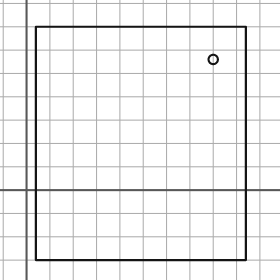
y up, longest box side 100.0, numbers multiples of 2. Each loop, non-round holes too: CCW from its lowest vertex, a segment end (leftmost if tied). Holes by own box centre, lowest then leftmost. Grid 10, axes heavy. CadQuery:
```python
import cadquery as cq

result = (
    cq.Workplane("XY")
    .moveTo(4.0, -30.0)
    .lineTo(94.0, -30.0)
    .lineTo(94.0, 70.0)
    .lineTo(4.0, 70.0)
    .close()
    .moveTo(80.0, 56.0)
    .circle(2.0)
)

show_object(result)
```